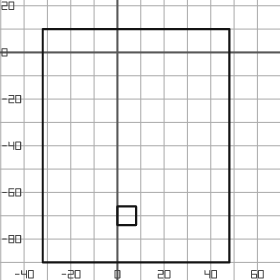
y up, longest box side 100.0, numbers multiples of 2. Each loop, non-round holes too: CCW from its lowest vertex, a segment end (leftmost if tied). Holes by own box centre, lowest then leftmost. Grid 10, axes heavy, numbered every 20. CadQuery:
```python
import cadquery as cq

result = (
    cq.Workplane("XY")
    .moveTo(-32.0, -90.0)
    .lineTo(48.0, -90.0)
    .lineTo(48.0, 10.0)
    .lineTo(-32.0, 10.0)
    .close()
    .moveTo(0.0, -74.0)
    .lineTo(8.0, -74.0)
    .lineTo(8.0, -66.0)
    .lineTo(0.0, -66.0)
    .close()
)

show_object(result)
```